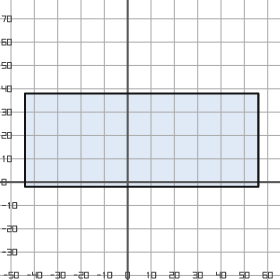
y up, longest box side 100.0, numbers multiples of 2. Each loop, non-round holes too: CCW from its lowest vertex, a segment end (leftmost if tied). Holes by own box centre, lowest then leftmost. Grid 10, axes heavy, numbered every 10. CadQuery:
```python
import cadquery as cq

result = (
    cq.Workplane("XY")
    .moveTo(-44.0, -2.0)
    .lineTo(56.0, -2.0)
    .lineTo(56.0, 38.0)
    .lineTo(-44.0, 38.0)
    .close()
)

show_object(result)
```